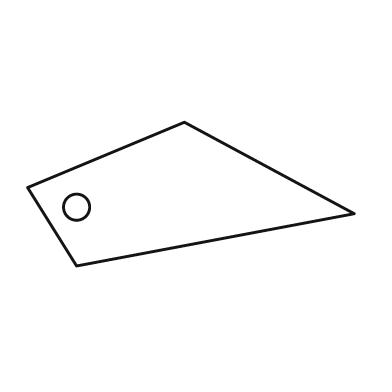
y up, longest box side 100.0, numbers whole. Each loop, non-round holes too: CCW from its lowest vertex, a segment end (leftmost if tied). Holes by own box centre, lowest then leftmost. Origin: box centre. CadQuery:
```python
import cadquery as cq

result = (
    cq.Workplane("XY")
    .moveTo(-35.0, -22.0)
    .lineTo(50.0, -6.0)
    .lineTo(-2.0, 22.0)
    .lineTo(-50.0, 2.0)
    .close()
    .moveTo(-35.0, -4.0)
    .circle(4.0)
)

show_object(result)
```